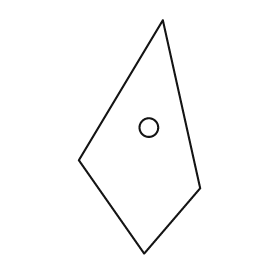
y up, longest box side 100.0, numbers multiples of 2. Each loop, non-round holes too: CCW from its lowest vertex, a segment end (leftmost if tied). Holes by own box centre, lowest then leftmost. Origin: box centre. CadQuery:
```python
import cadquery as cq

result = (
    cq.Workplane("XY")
    .moveTo(2.0, -50.0)
    .lineTo(26.0, -22.0)
    .lineTo(10.0, 50.0)
    .lineTo(-26.0, -10.0)
    .close()
    .moveTo(4.0, 4.0)
    .circle(4.0)
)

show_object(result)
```